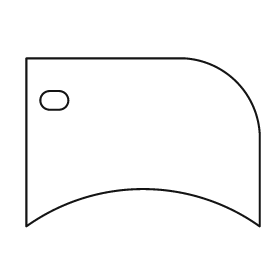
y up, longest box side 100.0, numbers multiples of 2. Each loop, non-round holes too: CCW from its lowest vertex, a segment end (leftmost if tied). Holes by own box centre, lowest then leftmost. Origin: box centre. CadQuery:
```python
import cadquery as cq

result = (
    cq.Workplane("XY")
    .moveTo(-50.0, -36.0)
    .threePointArc((0.0, -20.0), (50.0, -36.0))
    .lineTo(50.0, 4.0)
    .threePointArc((40.0, 26.0), (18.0, 36.0))
    .lineTo(-50.0, 36.0)
    .close()
    .moveTo(-40.0, 14.0)
    .lineTo(-36.0, 14.0)
    .threePointArc((-32.0, 18.0), (-36.0, 22.0))
    .lineTo(-40.0, 22.0)
    .threePointArc((-44.0, 18.0), (-40.0, 14.0))
    .close()
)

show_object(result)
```